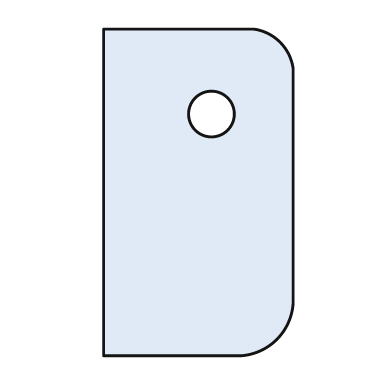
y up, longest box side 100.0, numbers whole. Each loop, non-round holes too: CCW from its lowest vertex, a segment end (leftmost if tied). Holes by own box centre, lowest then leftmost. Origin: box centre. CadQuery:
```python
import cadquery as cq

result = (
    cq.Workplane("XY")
    .moveTo(-29.0, -50.0)
    .lineTo(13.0, -50.0)
    .threePointArc((24.0, -45.0), (29.0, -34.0))
    .lineTo(29.0, 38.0)
    .threePointArc((25.0, 46.0), (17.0, 50.0))
    .lineTo(-29.0, 50.0)
    .close()
    .moveTo(4.0, 24.0)
    .circle(7.0)
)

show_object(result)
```